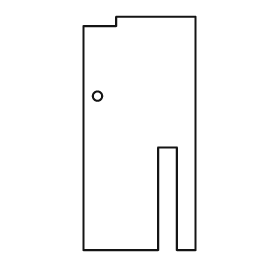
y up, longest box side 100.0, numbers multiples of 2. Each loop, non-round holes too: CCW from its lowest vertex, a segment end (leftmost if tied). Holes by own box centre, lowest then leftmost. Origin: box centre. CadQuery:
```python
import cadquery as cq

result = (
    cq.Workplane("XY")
    .moveTo(-24.0, -50.0)
    .lineTo(8.0, -50.0)
    .lineTo(8.0, -6.0)
    .lineTo(16.0, -6.0)
    .lineTo(16.0, -50.0)
    .lineTo(24.0, -50.0)
    .lineTo(24.0, 50.0)
    .lineTo(-10.0, 50.0)
    .lineTo(-10.0, 46.0)
    .lineTo(-24.0, 46.0)
    .close()
    .moveTo(-18.0, 16.0)
    .circle(2.0)
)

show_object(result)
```